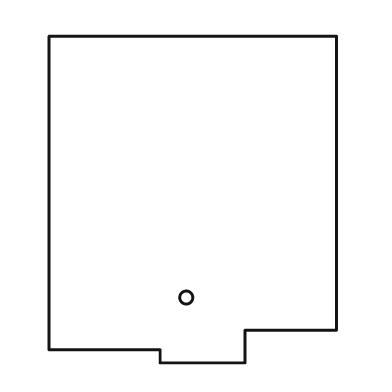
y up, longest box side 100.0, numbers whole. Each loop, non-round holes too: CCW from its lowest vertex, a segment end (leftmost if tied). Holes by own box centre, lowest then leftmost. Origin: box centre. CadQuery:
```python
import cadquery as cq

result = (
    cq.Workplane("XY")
    .moveTo(-10.0, -50.0)
    .lineTo(16.0, -50.0)
    .lineTo(16.0, -40.0)
    .lineTo(44.0, -40.0)
    .lineTo(44.0, 50.0)
    .lineTo(-44.0, 50.0)
    .lineTo(-44.0, -46.0)
    .lineTo(-10.0, -46.0)
    .close()
    .moveTo(-2.0, -30.0)
    .circle(2.0)
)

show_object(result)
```